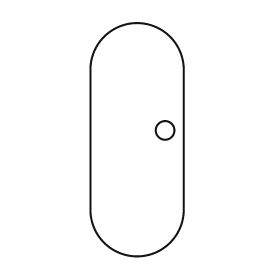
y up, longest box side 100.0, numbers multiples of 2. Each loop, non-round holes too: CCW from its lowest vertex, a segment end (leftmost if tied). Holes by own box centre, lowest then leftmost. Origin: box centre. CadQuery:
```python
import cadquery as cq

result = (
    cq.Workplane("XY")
    .moveTo(-20.0, -30.0)
    .threePointArc((0.0, -50.0), (20.0, -30.0))
    .lineTo(20.0, 30.0)
    .threePointArc((0.0, 50.0), (-20.0, 30.0))
    .close()
    .moveTo(12.0, 4.0)
    .circle(4.0)
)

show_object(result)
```